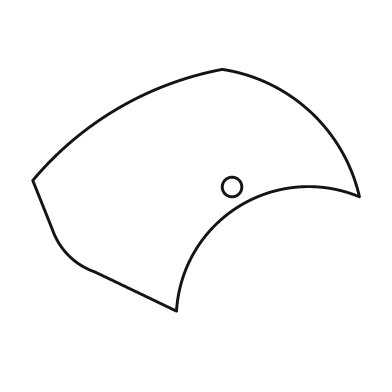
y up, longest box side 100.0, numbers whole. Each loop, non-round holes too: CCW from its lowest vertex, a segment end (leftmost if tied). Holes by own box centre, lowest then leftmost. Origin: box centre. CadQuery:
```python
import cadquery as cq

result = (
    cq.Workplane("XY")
    .moveTo(-6.0, -37.0)
    .threePointArc((13.0, -5.0), (50.0, -2.0))
    .threePointArc((35.0, 24.0), (8.0, 37.0))
    .threePointArc((-24.0, 25.0), (-50.0, 3.0))
    .lineTo(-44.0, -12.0)
    .threePointArc((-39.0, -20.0), (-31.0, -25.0))
    .close()
    .moveTo(11.0, 1.0)
    .circle(3.0)
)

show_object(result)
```